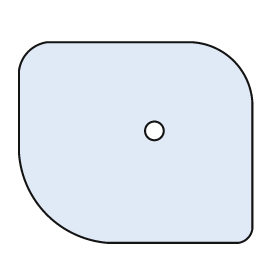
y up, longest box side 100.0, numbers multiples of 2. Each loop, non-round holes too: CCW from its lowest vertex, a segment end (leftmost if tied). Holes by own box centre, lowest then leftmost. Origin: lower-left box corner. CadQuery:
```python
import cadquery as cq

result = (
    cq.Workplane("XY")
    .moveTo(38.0, 0.0)
    .lineTo(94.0, 0.0)
    .threePointArc((98.0, 2.0), (100.0, 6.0))
    .lineTo(100.0, 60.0)
    .threePointArc((92.0, 78.0), (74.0, 86.0))
    .lineTo(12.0, 86.0)
    .threePointArc((4.0, 82.0), (0.0, 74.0))
    .lineTo(0.0, 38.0)
    .threePointArc((12.0, 12.0), (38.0, 0.0))
    .close()
    .moveTo(58.0, 48.0)
    .circle(4.0)
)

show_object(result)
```